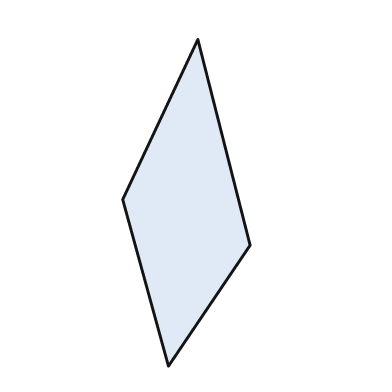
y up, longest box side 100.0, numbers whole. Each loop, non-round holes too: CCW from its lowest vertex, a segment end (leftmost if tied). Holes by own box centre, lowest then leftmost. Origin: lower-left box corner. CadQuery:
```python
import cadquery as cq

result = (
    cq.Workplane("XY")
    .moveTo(14.0, 0.0)
    .lineTo(39.0, 37.0)
    .lineTo(23.0, 100.0)
    .lineTo(0.0, 51.0)
    .close()
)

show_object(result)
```